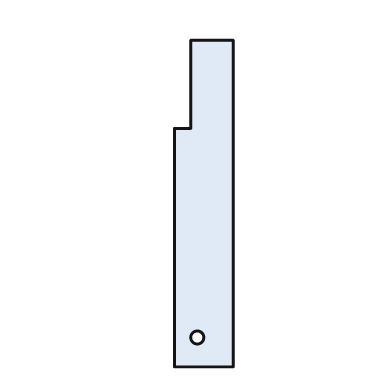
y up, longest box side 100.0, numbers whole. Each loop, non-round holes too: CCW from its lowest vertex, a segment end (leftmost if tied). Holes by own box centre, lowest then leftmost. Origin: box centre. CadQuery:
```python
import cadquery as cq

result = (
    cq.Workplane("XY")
    .moveTo(-9.0, -50.0)
    .lineTo(9.0, -50.0)
    .lineTo(9.0, 50.0)
    .lineTo(-4.0, 50.0)
    .lineTo(-4.0, 23.0)
    .lineTo(-9.0, 23.0)
    .close()
    .moveTo(-2.0, -41.0)
    .circle(2.0)
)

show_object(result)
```